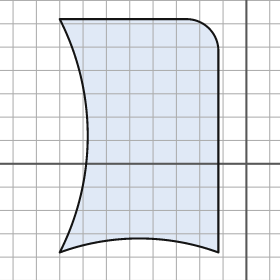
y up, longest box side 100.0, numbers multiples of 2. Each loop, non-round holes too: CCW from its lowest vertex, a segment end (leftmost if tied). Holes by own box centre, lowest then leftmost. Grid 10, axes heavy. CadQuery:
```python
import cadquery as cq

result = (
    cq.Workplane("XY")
    .moveTo(-80.0, -38.0)
    .threePointArc((-46.0, -32.0), (-12.0, -38.0))
    .lineTo(-12.0, 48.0)
    .threePointArc((-16.0, 58.0), (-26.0, 62.0))
    .lineTo(-80.0, 62.0)
    .threePointArc((-68.0, 12.0), (-80.0, -38.0))
    .close()
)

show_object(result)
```